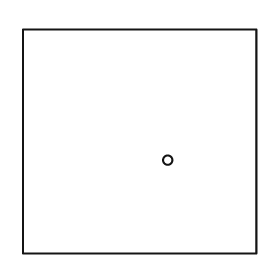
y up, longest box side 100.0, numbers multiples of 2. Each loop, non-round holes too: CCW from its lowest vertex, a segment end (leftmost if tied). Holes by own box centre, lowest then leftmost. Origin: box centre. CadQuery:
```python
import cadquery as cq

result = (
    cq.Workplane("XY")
    .moveTo(-50.0, -48.0)
    .lineTo(50.0, -48.0)
    .lineTo(50.0, 48.0)
    .lineTo(-50.0, 48.0)
    .close()
    .moveTo(12.0, -8.0)
    .circle(2.0)
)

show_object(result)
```